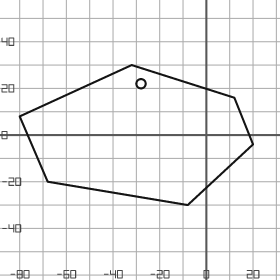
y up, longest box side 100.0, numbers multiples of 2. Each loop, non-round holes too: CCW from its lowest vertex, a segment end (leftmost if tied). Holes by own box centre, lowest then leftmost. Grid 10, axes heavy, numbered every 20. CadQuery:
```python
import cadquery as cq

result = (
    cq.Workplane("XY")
    .moveTo(-8.0, -30.0)
    .lineTo(20.0, -4.0)
    .lineTo(12.0, 16.0)
    .lineTo(-32.0, 30.0)
    .lineTo(-80.0, 8.0)
    .lineTo(-68.0, -20.0)
    .close()
    .moveTo(-28.0, 22.0)
    .circle(2.0)
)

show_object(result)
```